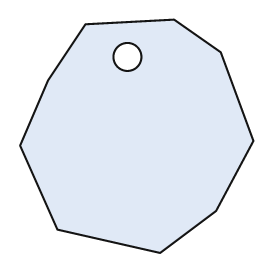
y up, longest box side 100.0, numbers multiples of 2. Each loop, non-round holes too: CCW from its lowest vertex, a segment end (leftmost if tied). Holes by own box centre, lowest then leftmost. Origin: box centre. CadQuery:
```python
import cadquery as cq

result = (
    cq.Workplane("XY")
    .moveTo(10.0, -50.0)
    .lineTo(34.0, -32.0)
    .lineTo(50.0, -2.0)
    .lineTo(36.0, 36.0)
    .lineTo(16.0, 50.0)
    .lineTo(-22.0, 48.0)
    .lineTo(-38.0, 24.0)
    .lineTo(-50.0, -4.0)
    .lineTo(-34.0, -40.0)
    .close()
    .moveTo(-4.0, 34.0)
    .circle(6.0)
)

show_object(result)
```